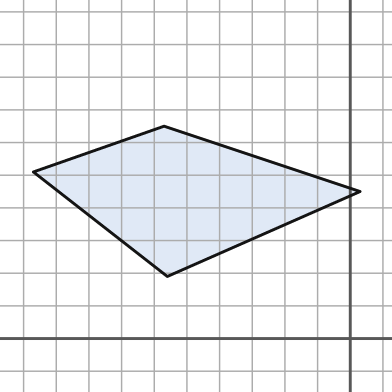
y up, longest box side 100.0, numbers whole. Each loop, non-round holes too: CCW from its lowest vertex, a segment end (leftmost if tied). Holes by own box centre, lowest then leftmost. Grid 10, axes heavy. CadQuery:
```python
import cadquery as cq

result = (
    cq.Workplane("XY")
    .moveTo(-56.0, 19.0)
    .lineTo(3.0, 45.0)
    .lineTo(-57.0, 65.0)
    .lineTo(-97.0, 51.0)
    .close()
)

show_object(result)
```